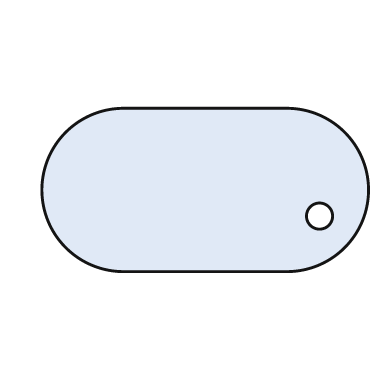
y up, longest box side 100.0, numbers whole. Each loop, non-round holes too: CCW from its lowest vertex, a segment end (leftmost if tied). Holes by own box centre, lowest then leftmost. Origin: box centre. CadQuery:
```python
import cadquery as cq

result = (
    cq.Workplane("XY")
    .moveTo(-25.0, -25.0)
    .lineTo(25.0, -25.0)
    .threePointArc((50.0, 0.0), (25.0, 25.0))
    .lineTo(-25.0, 25.0)
    .threePointArc((-50.0, 0.0), (-25.0, -25.0))
    .close()
    .moveTo(35.0, -8.0)
    .circle(4.0)
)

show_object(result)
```